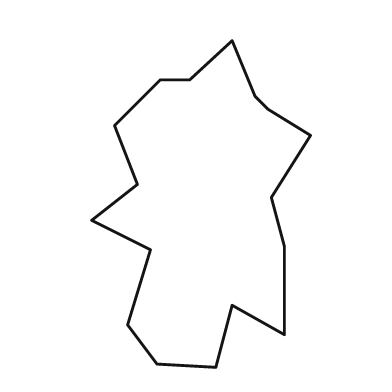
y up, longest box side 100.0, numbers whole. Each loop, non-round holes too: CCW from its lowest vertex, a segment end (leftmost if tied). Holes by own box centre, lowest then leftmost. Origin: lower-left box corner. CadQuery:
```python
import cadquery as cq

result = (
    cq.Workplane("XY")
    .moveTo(38.0, 0.0)
    .lineTo(43.0, 19.0)
    .lineTo(59.0, 10.0)
    .lineTo(59.0, 37.0)
    .lineTo(55.0, 52.0)
    .lineTo(67.0, 71.0)
    .lineTo(54.0, 79.0)
    .lineTo(50.0, 83.0)
    .lineTo(43.0, 100.0)
    .lineTo(30.0, 88.0)
    .lineTo(21.0, 88.0)
    .lineTo(7.0, 74.0)
    .lineTo(14.0, 56.0)
    .lineTo(0.0, 45.0)
    .lineTo(18.0, 36.0)
    .lineTo(11.0, 13.0)
    .lineTo(20.0, 1.0)
    .close()
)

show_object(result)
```